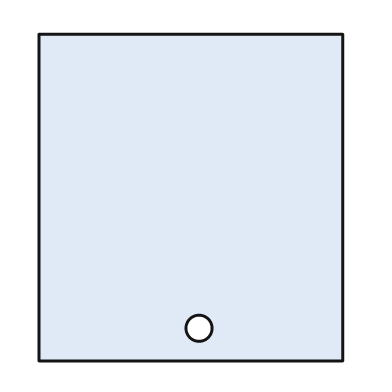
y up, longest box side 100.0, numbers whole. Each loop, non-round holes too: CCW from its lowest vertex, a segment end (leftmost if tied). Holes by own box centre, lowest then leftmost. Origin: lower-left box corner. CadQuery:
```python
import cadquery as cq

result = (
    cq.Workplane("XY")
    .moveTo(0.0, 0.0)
    .lineTo(93.0, 0.0)
    .lineTo(93.0, 100.0)
    .lineTo(0.0, 100.0)
    .close()
    .moveTo(49.0, 10.0)
    .circle(4.0)
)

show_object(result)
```